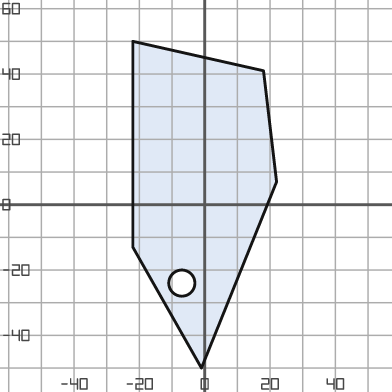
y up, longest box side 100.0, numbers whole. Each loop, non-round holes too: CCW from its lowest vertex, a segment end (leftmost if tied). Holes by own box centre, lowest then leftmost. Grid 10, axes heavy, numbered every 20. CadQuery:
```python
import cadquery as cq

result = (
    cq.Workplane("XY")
    .moveTo(-1.0, -50.0)
    .lineTo(22.0, 7.0)
    .lineTo(18.0, 41.0)
    .lineTo(-22.0, 50.0)
    .lineTo(-22.0, -13.0)
    .close()
    .moveTo(-7.0, -24.0)
    .circle(4.0)
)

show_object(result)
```